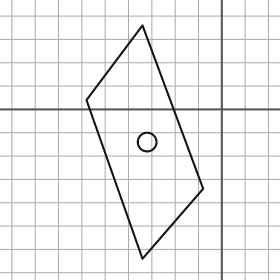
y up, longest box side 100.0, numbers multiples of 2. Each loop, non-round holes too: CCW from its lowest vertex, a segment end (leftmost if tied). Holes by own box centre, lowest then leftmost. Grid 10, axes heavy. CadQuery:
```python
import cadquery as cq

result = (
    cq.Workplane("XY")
    .moveTo(-34.0, -64.0)
    .lineTo(-8.0, -34.0)
    .lineTo(-34.0, 36.0)
    .lineTo(-58.0, 4.0)
    .close()
    .moveTo(-32.0, -14.0)
    .circle(4.0)
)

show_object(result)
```